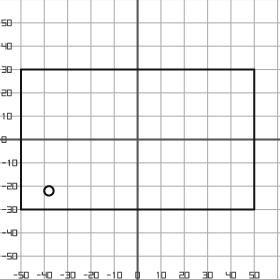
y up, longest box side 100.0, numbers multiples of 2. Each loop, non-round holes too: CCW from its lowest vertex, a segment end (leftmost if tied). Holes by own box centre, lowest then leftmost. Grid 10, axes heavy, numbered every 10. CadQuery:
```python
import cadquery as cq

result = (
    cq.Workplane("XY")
    .moveTo(-50.0, -30.0)
    .lineTo(50.0, -30.0)
    .lineTo(50.0, 30.0)
    .lineTo(-50.0, 30.0)
    .close()
    .moveTo(-38.0, -22.0)
    .circle(2.0)
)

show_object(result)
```